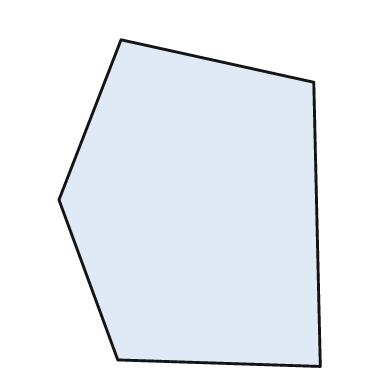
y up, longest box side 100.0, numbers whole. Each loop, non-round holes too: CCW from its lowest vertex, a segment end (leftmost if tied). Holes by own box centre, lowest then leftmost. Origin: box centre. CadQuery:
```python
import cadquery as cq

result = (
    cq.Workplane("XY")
    .moveTo(40.0, -50.0)
    .lineTo(38.0, 37.0)
    .lineTo(-21.0, 50.0)
    .lineTo(-40.0, 1.0)
    .lineTo(-22.0, -48.0)
    .close()
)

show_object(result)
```